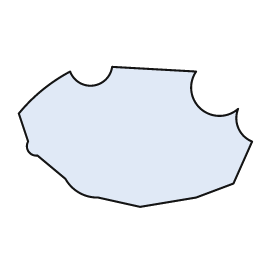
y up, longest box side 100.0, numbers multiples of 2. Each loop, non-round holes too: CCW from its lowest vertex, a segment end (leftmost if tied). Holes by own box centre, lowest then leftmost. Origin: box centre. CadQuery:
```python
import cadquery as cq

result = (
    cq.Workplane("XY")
    .moveTo(2.0, -30.0)
    .lineTo(26.0, -26.0)
    .lineTo(42.0, -20.0)
    .lineTo(50.0, -2.0)
    .threePointArc((44.0, 4.0), (44.0, 12.0))
    .threePointArc((28.0, 12.0), (26.0, 28.0))
    .lineTo(-10.0, 30.0)
    .threePointArc((-18.0, 22.0), (-28.0, 28.0))
    .threePointArc((-40.0, 20.0), (-50.0, 10.0))
    .lineTo(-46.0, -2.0)
    .threePointArc((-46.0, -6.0), (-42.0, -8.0))
    .lineTo(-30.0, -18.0)
    .threePointArc((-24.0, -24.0), (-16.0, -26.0))
    .close()
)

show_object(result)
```